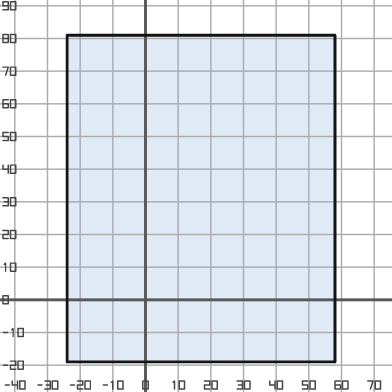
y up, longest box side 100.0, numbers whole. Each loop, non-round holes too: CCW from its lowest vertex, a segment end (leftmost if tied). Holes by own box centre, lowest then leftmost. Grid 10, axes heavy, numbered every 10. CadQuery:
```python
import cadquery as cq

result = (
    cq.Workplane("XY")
    .moveTo(-24.0, -19.0)
    .lineTo(58.0, -19.0)
    .lineTo(58.0, 81.0)
    .lineTo(-24.0, 81.0)
    .close()
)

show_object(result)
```